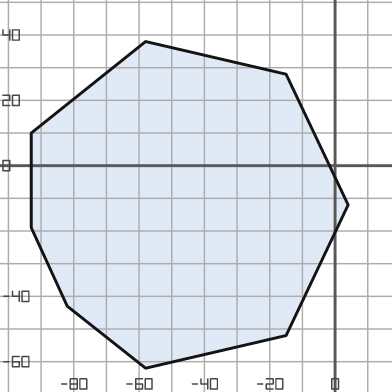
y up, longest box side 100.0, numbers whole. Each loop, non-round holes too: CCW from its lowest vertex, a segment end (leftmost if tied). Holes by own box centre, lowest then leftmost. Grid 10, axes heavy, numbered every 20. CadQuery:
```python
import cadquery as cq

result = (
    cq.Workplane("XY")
    .moveTo(-58.0, -62.0)
    .lineTo(-15.0, -52.0)
    .lineTo(4.0, -12.0)
    .lineTo(-15.0, 28.0)
    .lineTo(-58.0, 38.0)
    .lineTo(-93.0, 10.0)
    .lineTo(-93.0, -19.0)
    .lineTo(-82.0, -43.0)
    .close()
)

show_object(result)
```